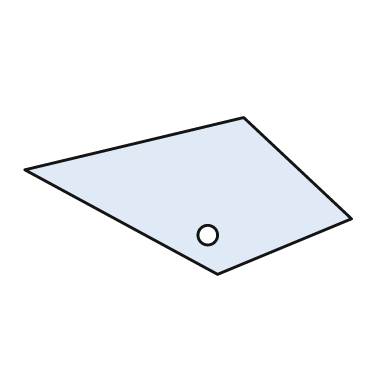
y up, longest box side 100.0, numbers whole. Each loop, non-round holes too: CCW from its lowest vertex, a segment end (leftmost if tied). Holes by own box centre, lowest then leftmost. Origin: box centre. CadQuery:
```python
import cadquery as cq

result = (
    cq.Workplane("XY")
    .moveTo(9.0, -24.0)
    .lineTo(50.0, -7.0)
    .lineTo(17.0, 24.0)
    .lineTo(-50.0, 8.0)
    .close()
    .moveTo(6.0, -12.0)
    .circle(3.0)
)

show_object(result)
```